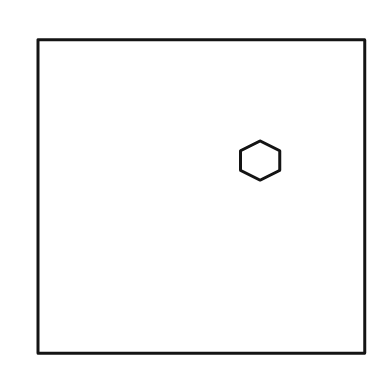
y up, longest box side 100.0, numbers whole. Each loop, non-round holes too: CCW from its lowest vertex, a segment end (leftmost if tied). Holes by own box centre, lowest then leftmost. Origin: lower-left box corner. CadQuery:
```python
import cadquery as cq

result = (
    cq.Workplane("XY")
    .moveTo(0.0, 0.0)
    .lineTo(100.0, 0.0)
    .lineTo(100.0, 96.0)
    .lineTo(0.0, 96.0)
    .close()
    .moveTo(68.0, 53.0)
    .lineTo(74.0, 56.0)
    .lineTo(74.0, 62.0)
    .lineTo(68.0, 65.0)
    .lineTo(62.0, 62.0)
    .lineTo(62.0, 56.0)
    .close()
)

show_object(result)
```